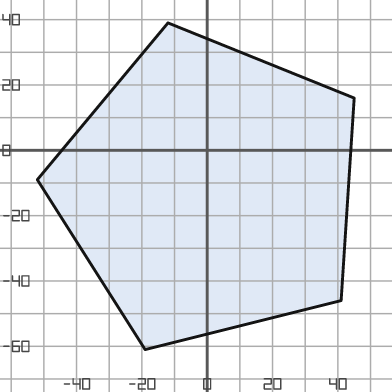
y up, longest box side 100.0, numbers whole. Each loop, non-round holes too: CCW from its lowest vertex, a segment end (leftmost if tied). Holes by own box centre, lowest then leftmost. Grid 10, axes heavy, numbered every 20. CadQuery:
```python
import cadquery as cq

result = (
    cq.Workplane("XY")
    .moveTo(-19.0, -61.0)
    .lineTo(41.0, -46.0)
    .lineTo(45.0, 16.0)
    .lineTo(-12.0, 39.0)
    .lineTo(-52.0, -9.0)
    .close()
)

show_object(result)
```